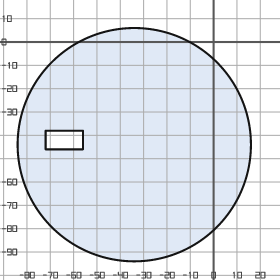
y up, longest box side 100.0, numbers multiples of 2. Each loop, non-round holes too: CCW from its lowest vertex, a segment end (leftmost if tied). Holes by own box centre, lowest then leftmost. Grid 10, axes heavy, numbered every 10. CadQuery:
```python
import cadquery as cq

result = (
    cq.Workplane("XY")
    .moveTo(-34.0, -44.0)
    .circle(50.0)
    .moveTo(-72.0, -46.0)
    .lineTo(-56.0, -46.0)
    .lineTo(-56.0, -38.0)
    .lineTo(-72.0, -38.0)
    .close()
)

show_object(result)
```